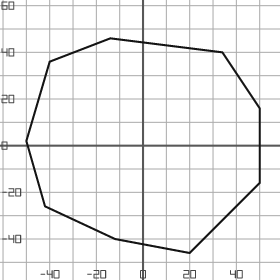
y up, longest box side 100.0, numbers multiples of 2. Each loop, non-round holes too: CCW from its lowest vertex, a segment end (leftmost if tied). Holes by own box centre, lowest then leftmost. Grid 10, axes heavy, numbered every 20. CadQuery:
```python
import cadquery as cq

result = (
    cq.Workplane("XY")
    .moveTo(20.0, -46.0)
    .lineTo(50.0, -16.0)
    .lineTo(50.0, 16.0)
    .lineTo(34.0, 40.0)
    .lineTo(-14.0, 46.0)
    .lineTo(-40.0, 36.0)
    .lineTo(-50.0, 2.0)
    .lineTo(-42.0, -26.0)
    .lineTo(-12.0, -40.0)
    .close()
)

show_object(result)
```